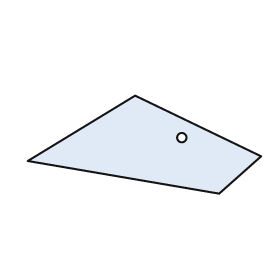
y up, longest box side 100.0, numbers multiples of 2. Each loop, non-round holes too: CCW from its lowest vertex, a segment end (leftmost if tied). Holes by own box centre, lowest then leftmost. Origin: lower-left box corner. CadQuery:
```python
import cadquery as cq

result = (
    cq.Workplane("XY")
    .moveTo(82.0, 0.0)
    .lineTo(100.0, 16.0)
    .lineTo(46.0, 42.0)
    .lineTo(0.0, 14.0)
    .close()
    .moveTo(66.0, 24.0)
    .circle(2.0)
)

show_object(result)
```